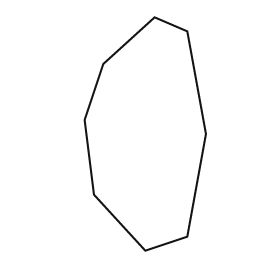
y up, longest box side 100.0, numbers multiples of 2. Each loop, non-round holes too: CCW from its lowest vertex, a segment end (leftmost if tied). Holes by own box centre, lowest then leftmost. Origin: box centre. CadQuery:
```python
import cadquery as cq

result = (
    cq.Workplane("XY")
    .moveTo(0.0, -50.0)
    .lineTo(18.0, -44.0)
    .lineTo(26.0, 0.0)
    .lineTo(18.0, 44.0)
    .lineTo(4.0, 50.0)
    .lineTo(-18.0, 30.0)
    .lineTo(-26.0, 6.0)
    .lineTo(-22.0, -26.0)
    .close()
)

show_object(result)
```